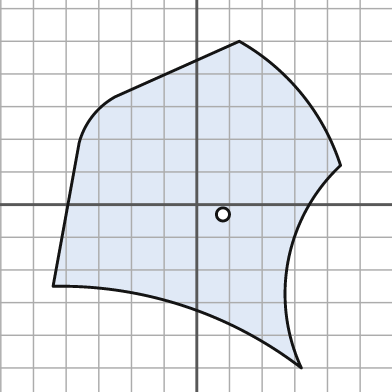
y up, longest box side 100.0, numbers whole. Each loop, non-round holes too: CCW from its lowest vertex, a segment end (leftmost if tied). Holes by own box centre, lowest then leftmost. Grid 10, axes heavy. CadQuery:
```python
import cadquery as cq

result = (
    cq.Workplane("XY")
    .moveTo(32.0, -50.0)
    .threePointArc((28.0, -17.0), (44.0, 12.0))
    .threePointArc((32.0, 34.0), (13.0, 50.0))
    .lineTo(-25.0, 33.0)
    .threePointArc((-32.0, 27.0), (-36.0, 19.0))
    .lineTo(-44.0, -25.0)
    .threePointArc((-4.0, -31.0), (32.0, -50.0))
    .close()
    .moveTo(8.0, -3.0)
    .circle(2.0)
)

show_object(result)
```